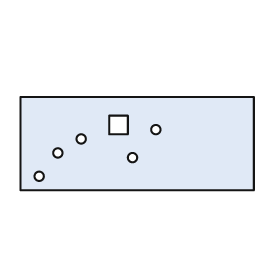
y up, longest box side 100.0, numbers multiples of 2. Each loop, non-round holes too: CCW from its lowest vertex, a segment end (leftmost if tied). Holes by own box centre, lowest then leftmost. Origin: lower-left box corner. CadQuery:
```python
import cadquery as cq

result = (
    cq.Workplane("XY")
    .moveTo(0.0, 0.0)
    .lineTo(100.0, 0.0)
    .lineTo(100.0, 40.0)
    .lineTo(0.0, 40.0)
    .close()
    .moveTo(8.0, 6.0)
    .circle(2.0)
    .moveTo(48.0, 14.0)
    .circle(2.0)
    .moveTo(16.0, 16.0)
    .circle(2.0)
    .moveTo(26.0, 22.0)
    .circle(2.0)
    .moveTo(58.0, 26.0)
    .circle(2.0)
    .moveTo(38.0, 24.0)
    .lineTo(46.0, 24.0)
    .lineTo(46.0, 32.0)
    .lineTo(38.0, 32.0)
    .close()
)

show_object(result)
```